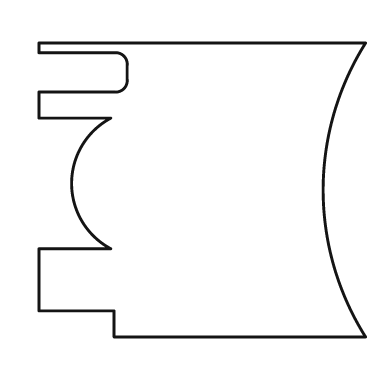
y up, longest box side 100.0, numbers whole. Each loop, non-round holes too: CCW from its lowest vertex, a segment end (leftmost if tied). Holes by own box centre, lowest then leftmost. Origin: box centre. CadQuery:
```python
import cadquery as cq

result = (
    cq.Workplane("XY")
    .moveTo(-27.0, -45.0)
    .lineTo(50.0, -45.0)
    .threePointArc((37.0, 0.0), (50.0, 45.0))
    .lineTo(-50.0, 45.0)
    .lineTo(-50.0, 42.0)
    .lineTo(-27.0, 42.0)
    .threePointArc((-24.0, 41.0), (-23.0, 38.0))
    .lineTo(-23.0, 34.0)
    .threePointArc((-24.0, 31.0), (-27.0, 30.0))
    .lineTo(-50.0, 30.0)
    .lineTo(-50.0, 22.0)
    .lineTo(-28.0, 22.0)
    .threePointArc((-40.0, 2.0), (-28.0, -18.0))
    .lineTo(-50.0, -18.0)
    .lineTo(-50.0, -37.0)
    .lineTo(-27.0, -37.0)
    .close()
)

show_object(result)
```